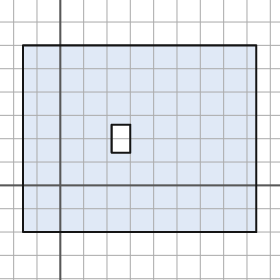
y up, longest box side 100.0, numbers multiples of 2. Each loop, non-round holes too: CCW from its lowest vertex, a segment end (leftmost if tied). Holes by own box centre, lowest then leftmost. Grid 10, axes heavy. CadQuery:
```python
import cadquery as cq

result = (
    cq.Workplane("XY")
    .moveTo(-16.0, -20.0)
    .lineTo(84.0, -20.0)
    .lineTo(84.0, 60.0)
    .lineTo(-16.0, 60.0)
    .close()
    .moveTo(22.0, 14.0)
    .lineTo(30.0, 14.0)
    .lineTo(30.0, 26.0)
    .lineTo(22.0, 26.0)
    .close()
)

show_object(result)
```